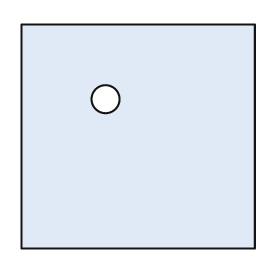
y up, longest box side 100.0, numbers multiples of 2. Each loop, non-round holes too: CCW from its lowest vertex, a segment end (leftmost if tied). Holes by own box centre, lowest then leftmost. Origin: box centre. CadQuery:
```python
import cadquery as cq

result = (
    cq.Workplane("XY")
    .moveTo(-50.0, -48.0)
    .lineTo(50.0, -48.0)
    .lineTo(50.0, 48.0)
    .lineTo(-50.0, 48.0)
    .close()
    .moveTo(-14.0, 16.0)
    .circle(6.0)
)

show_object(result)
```